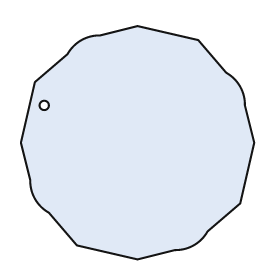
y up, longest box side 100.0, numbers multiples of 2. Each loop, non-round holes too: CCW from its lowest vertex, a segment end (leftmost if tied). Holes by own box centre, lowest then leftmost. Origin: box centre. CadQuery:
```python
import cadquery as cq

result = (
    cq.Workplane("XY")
    .moveTo(0.0, -50.0)
    .lineTo(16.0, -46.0)
    .threePointArc((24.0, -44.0), (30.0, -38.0))
    .lineTo(44.0, -26.0)
    .lineTo(50.0, 0.0)
    .lineTo(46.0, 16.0)
    .threePointArc((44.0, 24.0), (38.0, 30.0))
    .lineTo(26.0, 44.0)
    .lineTo(0.0, 50.0)
    .lineTo(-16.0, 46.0)
    .threePointArc((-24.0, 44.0), (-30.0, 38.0))
    .lineTo(-44.0, 26.0)
    .lineTo(-50.0, 0.0)
    .lineTo(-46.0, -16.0)
    .threePointArc((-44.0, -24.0), (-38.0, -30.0))
    .lineTo(-26.0, -44.0)
    .close()
    .moveTo(-40.0, 16.0)
    .circle(2.0)
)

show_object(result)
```